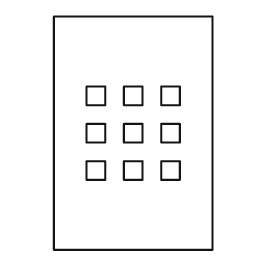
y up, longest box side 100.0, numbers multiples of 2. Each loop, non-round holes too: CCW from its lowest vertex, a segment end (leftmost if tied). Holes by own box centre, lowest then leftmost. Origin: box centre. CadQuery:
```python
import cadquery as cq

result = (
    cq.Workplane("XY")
    .moveTo(-34.0, -50.0)
    .lineTo(34.0, -50.0)
    .lineTo(34.0, 50.0)
    .lineTo(-34.0, 50.0)
    .close()
    .moveTo(-20.0, -20.0)
    .lineTo(-12.0, -20.0)
    .lineTo(-12.0, -12.0)
    .lineTo(-20.0, -12.0)
    .close()
    .moveTo(-4.0, -20.0)
    .lineTo(4.0, -20.0)
    .lineTo(4.0, -12.0)
    .lineTo(-4.0, -12.0)
    .close()
    .moveTo(12.0, -20.0)
    .lineTo(20.0, -20.0)
    .lineTo(20.0, -12.0)
    .lineTo(12.0, -12.0)
    .close()
    .moveTo(-20.0, -4.0)
    .lineTo(-12.0, -4.0)
    .lineTo(-12.0, 4.0)
    .lineTo(-20.0, 4.0)
    .close()
    .moveTo(-4.0, -4.0)
    .lineTo(4.0, -4.0)
    .lineTo(4.0, 4.0)
    .lineTo(-4.0, 4.0)
    .close()
    .moveTo(12.0, -4.0)
    .lineTo(20.0, -4.0)
    .lineTo(20.0, 4.0)
    .lineTo(12.0, 4.0)
    .close()
    .moveTo(-20.0, 12.0)
    .lineTo(-12.0, 12.0)
    .lineTo(-12.0, 20.0)
    .lineTo(-20.0, 20.0)
    .close()
    .moveTo(-4.0, 12.0)
    .lineTo(4.0, 12.0)
    .lineTo(4.0, 20.0)
    .lineTo(-4.0, 20.0)
    .close()
    .moveTo(12.0, 12.0)
    .lineTo(20.0, 12.0)
    .lineTo(20.0, 20.0)
    .lineTo(12.0, 20.0)
    .close()
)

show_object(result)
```